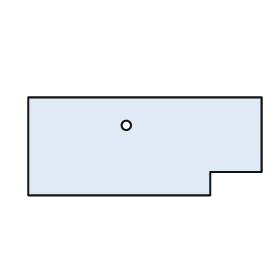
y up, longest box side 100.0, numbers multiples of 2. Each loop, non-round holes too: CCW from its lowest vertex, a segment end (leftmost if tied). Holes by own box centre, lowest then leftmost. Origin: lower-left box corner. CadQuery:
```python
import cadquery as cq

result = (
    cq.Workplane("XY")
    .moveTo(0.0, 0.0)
    .lineTo(78.0, 0.0)
    .lineTo(78.0, 10.0)
    .lineTo(100.0, 10.0)
    .lineTo(100.0, 42.0)
    .lineTo(0.0, 42.0)
    .close()
    .moveTo(42.0, 30.0)
    .circle(2.0)
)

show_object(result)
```